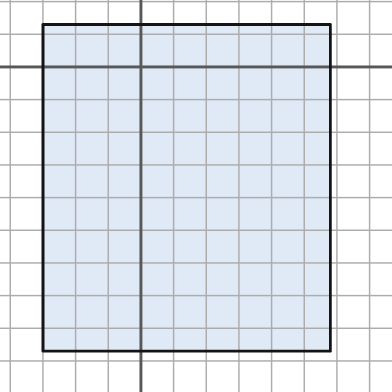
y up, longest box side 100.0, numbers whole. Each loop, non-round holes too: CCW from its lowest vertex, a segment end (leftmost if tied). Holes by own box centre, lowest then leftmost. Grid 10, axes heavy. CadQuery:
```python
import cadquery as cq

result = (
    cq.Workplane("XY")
    .moveTo(-30.0, -87.0)
    .lineTo(58.0, -87.0)
    .lineTo(58.0, 13.0)
    .lineTo(-30.0, 13.0)
    .close()
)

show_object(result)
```